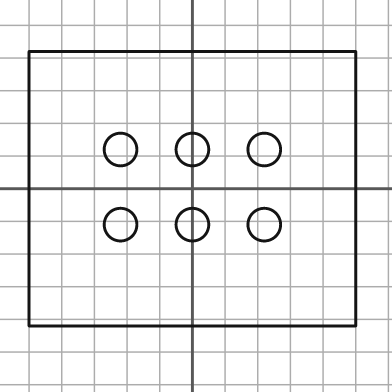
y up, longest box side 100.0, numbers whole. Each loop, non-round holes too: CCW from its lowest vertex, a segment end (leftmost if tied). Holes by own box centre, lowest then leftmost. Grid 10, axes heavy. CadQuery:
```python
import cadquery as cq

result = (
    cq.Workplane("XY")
    .moveTo(-50.0, -42.0)
    .lineTo(50.0, -42.0)
    .lineTo(50.0, 42.0)
    .lineTo(-50.0, 42.0)
    .close()
    .moveTo(-22.0, -11.0)
    .circle(5.0)
    .moveTo(0.0, -11.0)
    .circle(5.0)
    .moveTo(22.0, -11.0)
    .circle(5.0)
    .moveTo(-22.0, 12.0)
    .circle(5.0)
    .moveTo(0.0, 12.0)
    .circle(5.0)
    .moveTo(22.0, 12.0)
    .circle(5.0)
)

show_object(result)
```